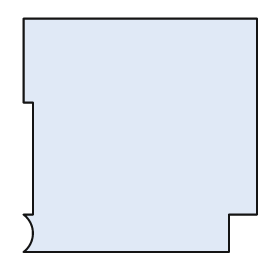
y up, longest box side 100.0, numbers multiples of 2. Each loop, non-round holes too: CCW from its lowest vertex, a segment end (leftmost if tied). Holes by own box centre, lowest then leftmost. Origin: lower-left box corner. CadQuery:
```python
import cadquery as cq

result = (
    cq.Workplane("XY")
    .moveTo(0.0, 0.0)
    .lineTo(88.0, 0.0)
    .lineTo(88.0, 16.0)
    .lineTo(100.0, 16.0)
    .lineTo(100.0, 100.0)
    .lineTo(0.0, 100.0)
    .lineTo(0.0, 64.0)
    .lineTo(4.0, 64.0)
    .lineTo(4.0, 16.0)
    .lineTo(0.0, 16.0)
    .threePointArc((4.0, 8.0), (0.0, 0.0))
    .close()
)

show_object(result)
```